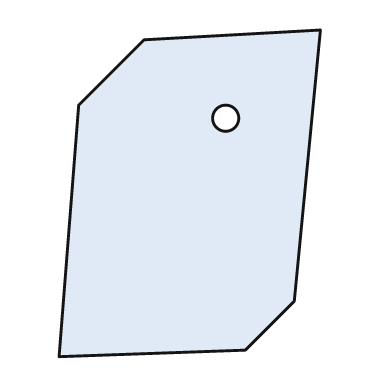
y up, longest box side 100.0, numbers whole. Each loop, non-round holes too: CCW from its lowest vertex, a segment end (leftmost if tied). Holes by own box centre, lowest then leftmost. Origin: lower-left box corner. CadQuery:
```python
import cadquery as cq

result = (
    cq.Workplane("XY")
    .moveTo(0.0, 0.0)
    .lineTo(57.0, 2.0)
    .lineTo(72.0, 17.0)
    .lineTo(80.0, 100.0)
    .lineTo(26.0, 97.0)
    .lineTo(6.0, 77.0)
    .close()
    .moveTo(51.0, 73.0)
    .circle(4.0)
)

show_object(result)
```